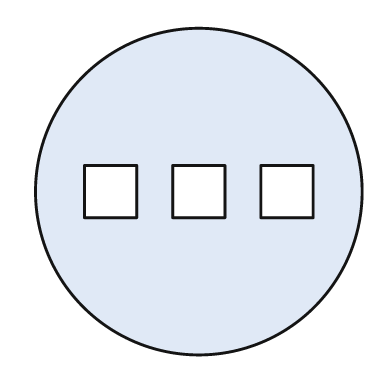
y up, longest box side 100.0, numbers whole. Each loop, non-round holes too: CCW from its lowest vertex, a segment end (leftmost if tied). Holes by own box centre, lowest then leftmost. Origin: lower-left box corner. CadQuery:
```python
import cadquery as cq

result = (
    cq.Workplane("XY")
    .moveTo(50.0, 50.0)
    .circle(50.0)
    .moveTo(15.0, 42.0)
    .lineTo(31.0, 42.0)
    .lineTo(31.0, 58.0)
    .lineTo(15.0, 58.0)
    .close()
    .moveTo(42.0, 42.0)
    .lineTo(58.0, 42.0)
    .lineTo(58.0, 58.0)
    .lineTo(42.0, 58.0)
    .close()
    .moveTo(69.0, 42.0)
    .lineTo(85.0, 42.0)
    .lineTo(85.0, 58.0)
    .lineTo(69.0, 58.0)
    .close()
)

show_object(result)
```